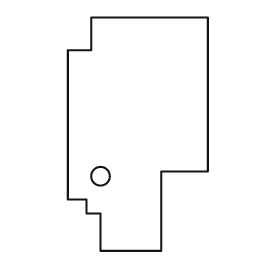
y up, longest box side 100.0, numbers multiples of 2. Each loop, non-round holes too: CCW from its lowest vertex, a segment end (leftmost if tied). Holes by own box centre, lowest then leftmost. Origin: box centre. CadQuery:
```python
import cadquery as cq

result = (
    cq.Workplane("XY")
    .moveTo(-16.0, -50.0)
    .lineTo(10.0, -50.0)
    .lineTo(10.0, -16.0)
    .lineTo(30.0, -16.0)
    .lineTo(30.0, 50.0)
    .lineTo(-20.0, 50.0)
    .lineTo(-20.0, 36.0)
    .lineTo(-30.0, 36.0)
    .lineTo(-30.0, -28.0)
    .lineTo(-22.0, -28.0)
    .lineTo(-22.0, -34.0)
    .lineTo(-16.0, -34.0)
    .close()
    .moveTo(-16.0, -18.0)
    .circle(4.0)
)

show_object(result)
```